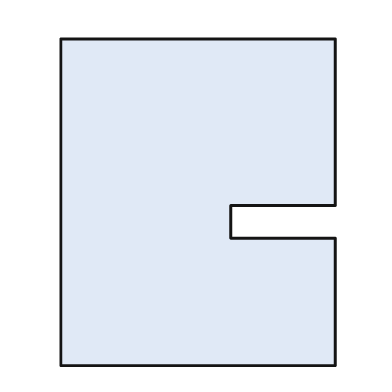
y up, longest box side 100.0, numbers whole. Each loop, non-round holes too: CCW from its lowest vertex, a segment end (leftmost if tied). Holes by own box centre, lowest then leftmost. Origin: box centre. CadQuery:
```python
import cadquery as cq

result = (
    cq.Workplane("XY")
    .moveTo(-42.0, -50.0)
    .lineTo(42.0, -50.0)
    .lineTo(42.0, -11.0)
    .lineTo(10.0, -11.0)
    .lineTo(10.0, -1.0)
    .lineTo(42.0, -1.0)
    .lineTo(42.0, 50.0)
    .lineTo(-42.0, 50.0)
    .close()
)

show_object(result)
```